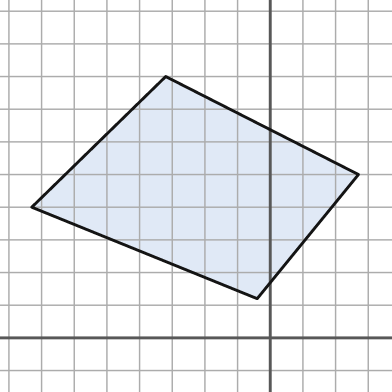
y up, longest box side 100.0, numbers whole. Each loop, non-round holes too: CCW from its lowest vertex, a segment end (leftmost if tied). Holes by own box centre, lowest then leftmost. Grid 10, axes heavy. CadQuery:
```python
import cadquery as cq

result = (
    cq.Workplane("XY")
    .moveTo(-4.0, 12.0)
    .lineTo(27.0, 50.0)
    .lineTo(-32.0, 80.0)
    .lineTo(-73.0, 40.0)
    .close()
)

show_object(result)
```